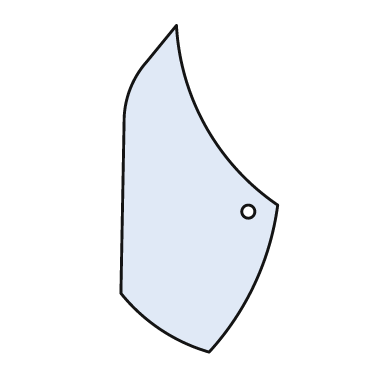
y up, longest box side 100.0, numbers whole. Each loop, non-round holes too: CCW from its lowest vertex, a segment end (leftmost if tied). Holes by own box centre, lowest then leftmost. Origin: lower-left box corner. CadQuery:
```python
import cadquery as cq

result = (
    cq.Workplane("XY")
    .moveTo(27.0, 0.0)
    .threePointArc((41.0, 21.0), (48.0, 45.0))
    .threePointArc((26.0, 69.0), (17.0, 100.0))
    .lineTo(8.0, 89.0)
    .threePointArc((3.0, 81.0), (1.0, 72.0))
    .lineTo(0.0, 18.0)
    .threePointArc((12.0, 7.0), (27.0, 0.0))
    .close()
    .moveTo(39.0, 43.0)
    .circle(2.0)
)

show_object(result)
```